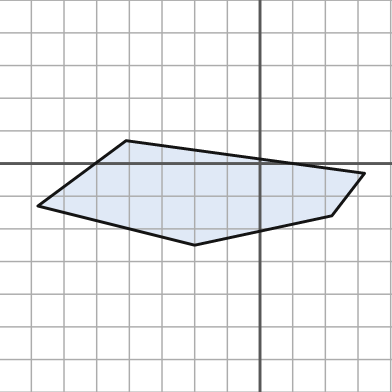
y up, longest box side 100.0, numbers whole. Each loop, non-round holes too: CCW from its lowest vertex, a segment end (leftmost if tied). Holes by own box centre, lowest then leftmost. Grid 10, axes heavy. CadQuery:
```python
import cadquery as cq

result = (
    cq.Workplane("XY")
    .moveTo(-20.0, -25.0)
    .lineTo(22.0, -16.0)
    .lineTo(32.0, -3.0)
    .lineTo(-41.0, 7.0)
    .lineTo(-68.0, -13.0)
    .close()
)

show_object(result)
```